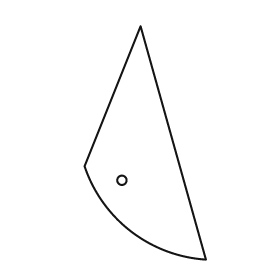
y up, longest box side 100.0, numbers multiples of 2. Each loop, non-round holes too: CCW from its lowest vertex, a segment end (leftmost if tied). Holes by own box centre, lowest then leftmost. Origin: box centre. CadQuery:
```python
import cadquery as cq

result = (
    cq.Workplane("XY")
    .moveTo(26.0, -50.0)
    .lineTo(-2.0, 50.0)
    .lineTo(-26.0, -10.0)
    .threePointArc((-6.0, -38.0), (26.0, -50.0))
    .close()
    .moveTo(-10.0, -16.0)
    .circle(2.0)
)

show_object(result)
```